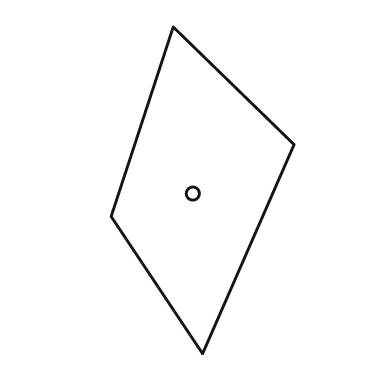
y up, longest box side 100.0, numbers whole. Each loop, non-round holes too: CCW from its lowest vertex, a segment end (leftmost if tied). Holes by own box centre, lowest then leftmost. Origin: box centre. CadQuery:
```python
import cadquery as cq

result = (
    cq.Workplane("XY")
    .moveTo(0.0, -50.0)
    .lineTo(28.0, 14.0)
    .lineTo(-9.0, 50.0)
    .lineTo(-28.0, -8.0)
    .close()
    .moveTo(-3.0, -1.0)
    .circle(2.0)
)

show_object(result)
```